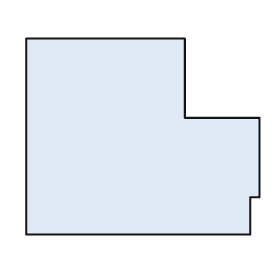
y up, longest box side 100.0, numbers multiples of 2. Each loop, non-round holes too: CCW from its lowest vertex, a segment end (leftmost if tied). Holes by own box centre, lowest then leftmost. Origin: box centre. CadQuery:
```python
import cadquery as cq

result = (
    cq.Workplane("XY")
    .moveTo(-50.0, -42.0)
    .lineTo(46.0, -42.0)
    .lineTo(46.0, -26.0)
    .lineTo(50.0, -26.0)
    .lineTo(50.0, 8.0)
    .lineTo(18.0, 8.0)
    .lineTo(18.0, 42.0)
    .lineTo(-50.0, 42.0)
    .close()
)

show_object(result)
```